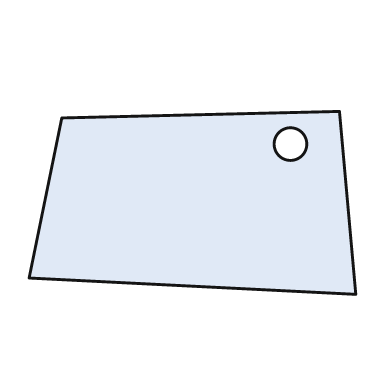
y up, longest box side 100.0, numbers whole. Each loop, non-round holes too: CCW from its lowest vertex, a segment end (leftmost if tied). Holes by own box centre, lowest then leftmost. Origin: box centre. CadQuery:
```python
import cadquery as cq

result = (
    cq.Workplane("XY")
    .moveTo(50.0, -28.0)
    .lineTo(45.0, 28.0)
    .lineTo(-40.0, 26.0)
    .lineTo(-50.0, -23.0)
    .close()
    .moveTo(30.0, 18.0)
    .circle(5.0)
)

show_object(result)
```